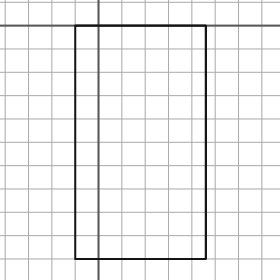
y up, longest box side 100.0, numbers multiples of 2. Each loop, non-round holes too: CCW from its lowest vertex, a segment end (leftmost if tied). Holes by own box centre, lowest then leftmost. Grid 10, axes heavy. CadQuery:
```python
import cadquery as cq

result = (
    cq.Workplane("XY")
    .moveTo(-10.0, -100.0)
    .lineTo(46.0, -100.0)
    .lineTo(46.0, 0.0)
    .lineTo(-10.0, 0.0)
    .close()
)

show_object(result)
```